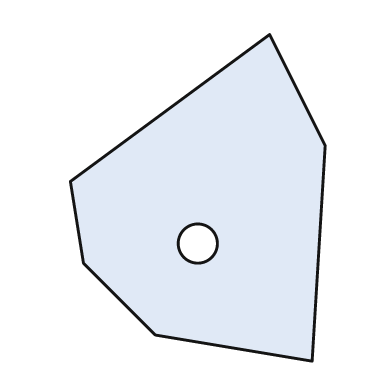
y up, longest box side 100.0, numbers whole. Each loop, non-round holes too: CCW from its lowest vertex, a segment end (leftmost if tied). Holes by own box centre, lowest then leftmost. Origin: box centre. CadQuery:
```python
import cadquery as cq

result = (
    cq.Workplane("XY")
    .moveTo(35.0, -50.0)
    .lineTo(39.0, 16.0)
    .lineTo(22.0, 50.0)
    .lineTo(-39.0, 5.0)
    .lineTo(-35.0, -20.0)
    .lineTo(-13.0, -42.0)
    .close()
    .moveTo(0.0, -14.0)
    .circle(6.0)
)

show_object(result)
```